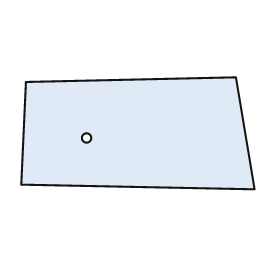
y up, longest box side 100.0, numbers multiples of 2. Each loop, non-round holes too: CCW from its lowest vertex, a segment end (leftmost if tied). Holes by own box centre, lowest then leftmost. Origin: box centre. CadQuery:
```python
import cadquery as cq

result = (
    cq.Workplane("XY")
    .moveTo(50.0, -24.0)
    .lineTo(42.0, 24.0)
    .lineTo(-48.0, 22.0)
    .lineTo(-50.0, -22.0)
    .close()
    .moveTo(-22.0, -2.0)
    .circle(2.0)
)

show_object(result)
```